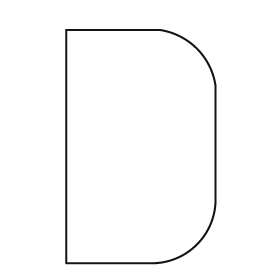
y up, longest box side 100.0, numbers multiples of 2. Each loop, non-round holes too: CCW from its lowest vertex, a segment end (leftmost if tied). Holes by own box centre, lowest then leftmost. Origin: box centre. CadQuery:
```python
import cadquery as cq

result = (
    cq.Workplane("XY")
    .moveTo(-32.0, -50.0)
    .lineTo(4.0, -50.0)
    .threePointArc((24.0, -42.0), (32.0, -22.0))
    .lineTo(32.0, 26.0)
    .threePointArc((24.0, 42.0), (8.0, 50.0))
    .lineTo(-32.0, 50.0)
    .close()
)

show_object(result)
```